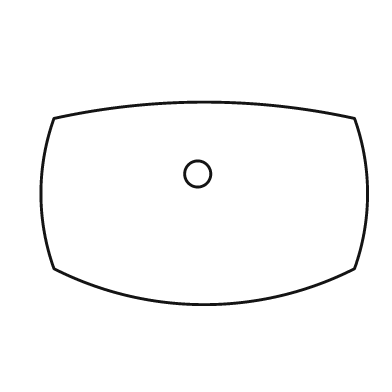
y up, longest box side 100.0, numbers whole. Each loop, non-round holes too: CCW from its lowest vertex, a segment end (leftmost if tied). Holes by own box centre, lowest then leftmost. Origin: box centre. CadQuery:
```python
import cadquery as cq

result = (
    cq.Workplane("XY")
    .moveTo(-46.0, -20.0)
    .threePointArc((0.0, -31.0), (46.0, -20.0))
    .threePointArc((50.0, 3.0), (46.0, 26.0))
    .threePointArc((0.0, 31.0), (-46.0, 26.0))
    .threePointArc((-50.0, 3.0), (-46.0, -20.0))
    .close()
    .moveTo(-2.0, 9.0)
    .circle(4.0)
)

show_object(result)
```